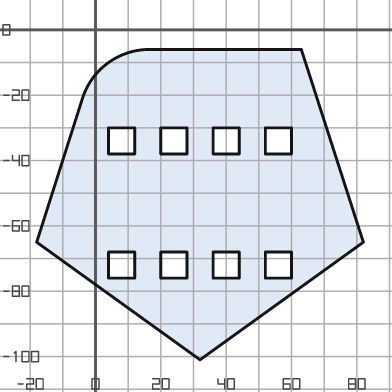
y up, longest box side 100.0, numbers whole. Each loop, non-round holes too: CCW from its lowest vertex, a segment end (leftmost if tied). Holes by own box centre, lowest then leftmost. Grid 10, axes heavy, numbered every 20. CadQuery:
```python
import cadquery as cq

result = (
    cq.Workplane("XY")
    .moveTo(32.0, -101.0)
    .lineTo(82.0, -65.0)
    .lineTo(63.0, -6.0)
    .lineTo(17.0, -6.0)
    .threePointArc((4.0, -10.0), (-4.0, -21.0))
    .lineTo(-18.0, -65.0)
    .close()
    .moveTo(4.0, -76.0)
    .lineTo(12.0, -76.0)
    .lineTo(12.0, -68.0)
    .lineTo(4.0, -68.0)
    .close()
    .moveTo(20.0, -76.0)
    .lineTo(28.0, -76.0)
    .lineTo(28.0, -68.0)
    .lineTo(20.0, -68.0)
    .close()
    .moveTo(36.0, -76.0)
    .lineTo(44.0, -76.0)
    .lineTo(44.0, -68.0)
    .lineTo(36.0, -68.0)
    .close()
    .moveTo(52.0, -76.0)
    .lineTo(60.0, -76.0)
    .lineTo(60.0, -68.0)
    .lineTo(52.0, -68.0)
    .close()
    .moveTo(4.0, -38.0)
    .lineTo(12.0, -38.0)
    .lineTo(12.0, -30.0)
    .lineTo(4.0, -30.0)
    .close()
    .moveTo(20.0, -38.0)
    .lineTo(28.0, -38.0)
    .lineTo(28.0, -30.0)
    .lineTo(20.0, -30.0)
    .close()
    .moveTo(36.0, -38.0)
    .lineTo(44.0, -38.0)
    .lineTo(44.0, -30.0)
    .lineTo(36.0, -30.0)
    .close()
    .moveTo(52.0, -38.0)
    .lineTo(60.0, -38.0)
    .lineTo(60.0, -30.0)
    .lineTo(52.0, -30.0)
    .close()
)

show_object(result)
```